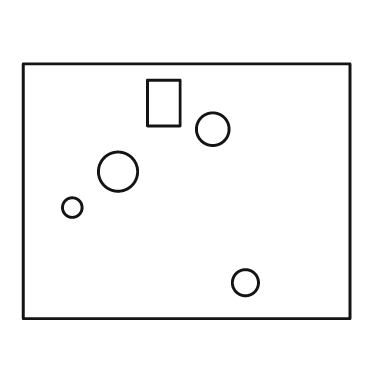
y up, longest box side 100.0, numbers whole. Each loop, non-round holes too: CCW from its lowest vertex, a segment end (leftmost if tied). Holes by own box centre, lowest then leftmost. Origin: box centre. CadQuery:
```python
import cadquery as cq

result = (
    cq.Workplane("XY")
    .moveTo(-50.0, -39.0)
    .lineTo(50.0, -39.0)
    .lineTo(50.0, 39.0)
    .lineTo(-50.0, 39.0)
    .close()
    .moveTo(18.0, -28.0)
    .circle(4.0)
    .moveTo(-35.0, -5.0)
    .circle(3.0)
    .moveTo(-21.0, 6.0)
    .circle(6.0)
    .moveTo(8.0, 19.0)
    .circle(5.0)
    .moveTo(-12.0, 20.0)
    .lineTo(-2.0, 20.0)
    .lineTo(-2.0, 34.0)
    .lineTo(-12.0, 34.0)
    .close()
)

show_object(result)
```